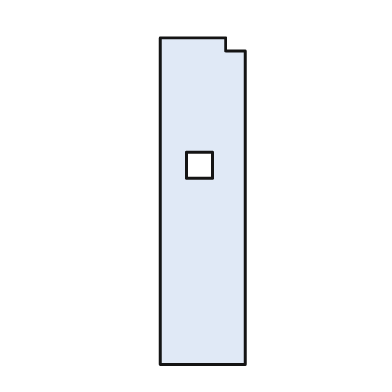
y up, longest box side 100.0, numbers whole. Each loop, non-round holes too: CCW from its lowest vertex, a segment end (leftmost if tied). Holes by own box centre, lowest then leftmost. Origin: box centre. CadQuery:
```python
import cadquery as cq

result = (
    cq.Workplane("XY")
    .moveTo(-13.0, -50.0)
    .lineTo(13.0, -50.0)
    .lineTo(13.0, 46.0)
    .lineTo(7.0, 46.0)
    .lineTo(7.0, 50.0)
    .lineTo(-13.0, 50.0)
    .close()
    .moveTo(-5.0, 7.0)
    .lineTo(3.0, 7.0)
    .lineTo(3.0, 15.0)
    .lineTo(-5.0, 15.0)
    .close()
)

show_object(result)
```